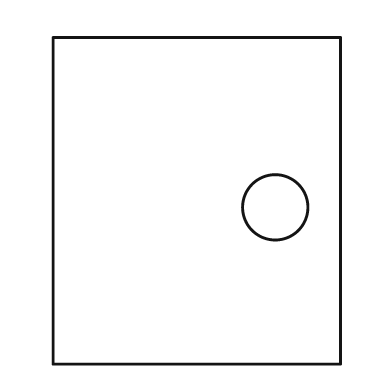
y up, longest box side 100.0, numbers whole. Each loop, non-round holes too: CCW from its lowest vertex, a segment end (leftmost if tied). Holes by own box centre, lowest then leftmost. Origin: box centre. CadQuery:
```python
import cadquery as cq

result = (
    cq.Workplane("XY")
    .moveTo(-44.0, -50.0)
    .lineTo(44.0, -50.0)
    .lineTo(44.0, 50.0)
    .lineTo(-44.0, 50.0)
    .close()
    .moveTo(24.0, -2.0)
    .circle(10.0)
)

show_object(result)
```